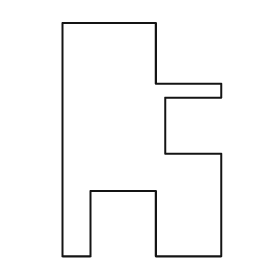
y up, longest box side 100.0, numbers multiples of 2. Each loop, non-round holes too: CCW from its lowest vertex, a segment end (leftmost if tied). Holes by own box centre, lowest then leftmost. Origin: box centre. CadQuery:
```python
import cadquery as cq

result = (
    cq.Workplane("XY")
    .moveTo(-34.0, -50.0)
    .lineTo(-22.0, -50.0)
    .lineTo(-22.0, -22.0)
    .lineTo(6.0, -22.0)
    .lineTo(6.0, -50.0)
    .lineTo(34.0, -50.0)
    .lineTo(34.0, -6.0)
    .lineTo(10.0, -6.0)
    .lineTo(10.0, 18.0)
    .lineTo(34.0, 18.0)
    .lineTo(34.0, 24.0)
    .lineTo(6.0, 24.0)
    .lineTo(6.0, 50.0)
    .lineTo(-34.0, 50.0)
    .close()
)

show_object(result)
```